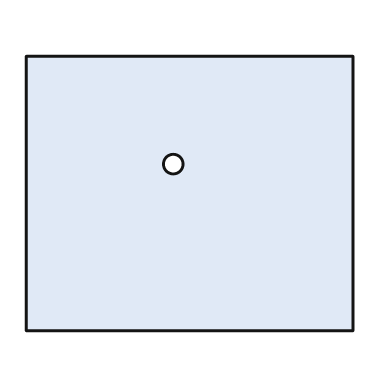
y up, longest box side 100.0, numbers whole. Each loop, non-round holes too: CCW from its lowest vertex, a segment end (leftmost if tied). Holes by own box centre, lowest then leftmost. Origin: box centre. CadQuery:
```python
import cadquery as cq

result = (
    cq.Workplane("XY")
    .moveTo(-50.0, -42.0)
    .lineTo(50.0, -42.0)
    .lineTo(50.0, 42.0)
    .lineTo(-50.0, 42.0)
    .close()
    .moveTo(-5.0, 9.0)
    .circle(3.0)
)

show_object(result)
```